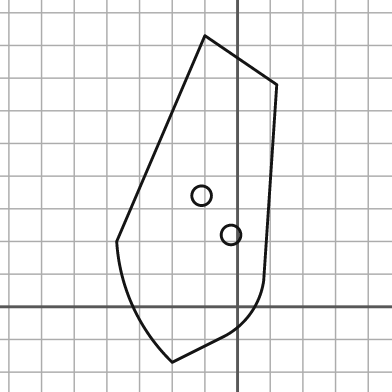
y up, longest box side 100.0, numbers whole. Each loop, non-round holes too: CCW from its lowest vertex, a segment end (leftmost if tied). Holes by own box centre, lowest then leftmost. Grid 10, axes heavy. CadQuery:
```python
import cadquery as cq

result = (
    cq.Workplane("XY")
    .moveTo(-20.0, -17.0)
    .lineTo(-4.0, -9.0)
    .threePointArc((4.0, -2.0), (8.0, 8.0))
    .lineTo(12.0, 68.0)
    .lineTo(-10.0, 83.0)
    .lineTo(-37.0, 20.0)
    .threePointArc((-32.0, 0.0), (-20.0, -17.0))
    .close()
    .moveTo(-2.0, 22.0)
    .circle(3.0)
    .moveTo(-11.0, 34.0)
    .circle(3.0)
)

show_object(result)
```